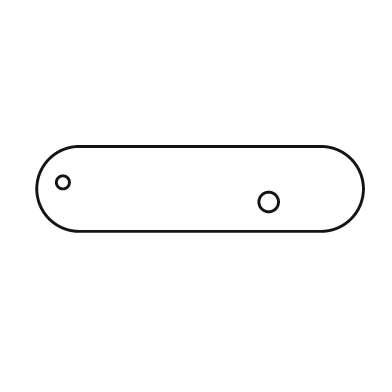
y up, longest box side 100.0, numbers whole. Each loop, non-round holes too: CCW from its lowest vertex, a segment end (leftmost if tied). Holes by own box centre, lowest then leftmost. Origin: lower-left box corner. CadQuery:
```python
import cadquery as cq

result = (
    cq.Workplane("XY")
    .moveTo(13.0, 0.0)
    .lineTo(87.0, 0.0)
    .threePointArc((100.0, 13.0), (87.0, 26.0))
    .lineTo(13.0, 26.0)
    .threePointArc((0.0, 13.0), (13.0, 0.0))
    .close()
    .moveTo(71.0, 9.0)
    .circle(3.0)
    .moveTo(8.0, 15.0)
    .circle(2.0)
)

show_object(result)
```